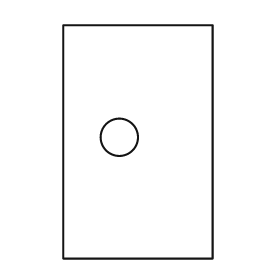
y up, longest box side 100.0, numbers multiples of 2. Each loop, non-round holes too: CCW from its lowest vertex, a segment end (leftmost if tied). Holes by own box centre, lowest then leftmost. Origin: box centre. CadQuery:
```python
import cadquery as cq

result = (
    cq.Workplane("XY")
    .moveTo(-32.0, -50.0)
    .lineTo(32.0, -50.0)
    .lineTo(32.0, 50.0)
    .lineTo(-32.0, 50.0)
    .close()
    .moveTo(-8.0, 2.0)
    .circle(8.0)
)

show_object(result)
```